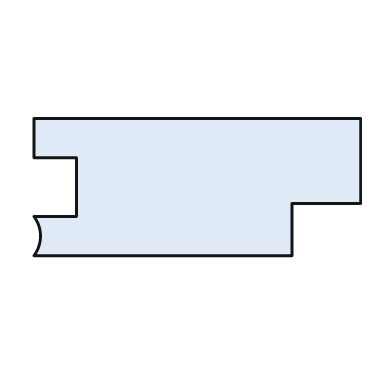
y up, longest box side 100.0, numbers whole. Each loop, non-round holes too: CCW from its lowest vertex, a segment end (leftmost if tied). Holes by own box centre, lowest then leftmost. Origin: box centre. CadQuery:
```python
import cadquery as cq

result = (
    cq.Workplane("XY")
    .moveTo(-50.0, -21.0)
    .lineTo(29.0, -21.0)
    .lineTo(29.0, -5.0)
    .lineTo(50.0, -5.0)
    .lineTo(50.0, 21.0)
    .lineTo(-50.0, 21.0)
    .lineTo(-50.0, 9.0)
    .lineTo(-37.0, 9.0)
    .lineTo(-37.0, -9.0)
    .lineTo(-50.0, -9.0)
    .threePointArc((-48.0, -15.0), (-50.0, -21.0))
    .close()
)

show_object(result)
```